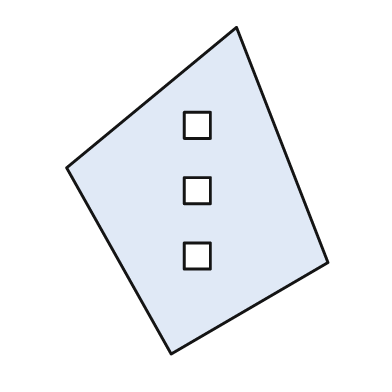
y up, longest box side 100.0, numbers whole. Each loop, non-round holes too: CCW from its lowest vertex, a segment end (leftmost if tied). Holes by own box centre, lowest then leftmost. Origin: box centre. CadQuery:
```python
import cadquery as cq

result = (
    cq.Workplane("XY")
    .moveTo(-8.0, -50.0)
    .lineTo(40.0, -22.0)
    .lineTo(12.0, 50.0)
    .lineTo(-40.0, 7.0)
    .close()
    .moveTo(-4.0, -24.0)
    .lineTo(4.0, -24.0)
    .lineTo(4.0, -16.0)
    .lineTo(-4.0, -16.0)
    .close()
    .moveTo(-4.0, -4.0)
    .lineTo(4.0, -4.0)
    .lineTo(4.0, 4.0)
    .lineTo(-4.0, 4.0)
    .close()
    .moveTo(-4.0, 16.0)
    .lineTo(4.0, 16.0)
    .lineTo(4.0, 24.0)
    .lineTo(-4.0, 24.0)
    .close()
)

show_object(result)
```